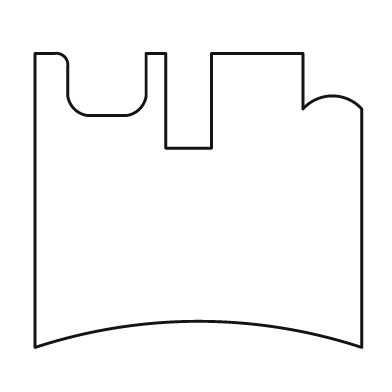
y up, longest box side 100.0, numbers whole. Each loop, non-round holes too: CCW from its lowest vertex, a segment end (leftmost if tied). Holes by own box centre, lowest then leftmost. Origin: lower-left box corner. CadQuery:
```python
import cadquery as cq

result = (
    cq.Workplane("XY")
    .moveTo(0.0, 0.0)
    .threePointArc((50.0, 8.0), (100.0, 0.0))
    .lineTo(100.0, 73.0)
    .threePointArc((91.0, 77.0), (82.0, 73.0))
    .lineTo(82.0, 90.0)
    .lineTo(54.0, 90.0)
    .lineTo(54.0, 61.0)
    .lineTo(40.0, 61.0)
    .lineTo(40.0, 90.0)
    .lineTo(34.0, 90.0)
    .lineTo(34.0, 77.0)
    .threePointArc((32.0, 73.0), (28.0, 71.0))
    .lineTo(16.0, 71.0)
    .threePointArc((12.0, 73.0), (10.0, 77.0))
    .lineTo(10.0, 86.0)
    .threePointArc((9.0, 89.0), (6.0, 90.0))
    .lineTo(0.0, 90.0)
    .close()
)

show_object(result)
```